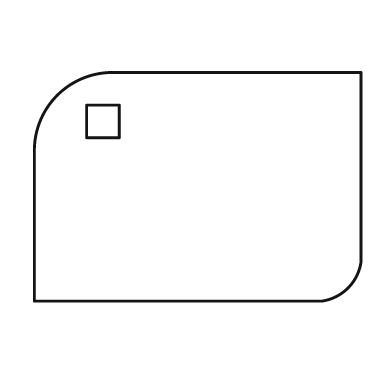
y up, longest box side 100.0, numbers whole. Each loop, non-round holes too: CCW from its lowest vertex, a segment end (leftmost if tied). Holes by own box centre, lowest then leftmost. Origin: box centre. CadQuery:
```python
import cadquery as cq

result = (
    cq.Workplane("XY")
    .moveTo(-50.0, -35.0)
    .lineTo(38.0, -35.0)
    .threePointArc((46.0, -31.0), (50.0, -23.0))
    .lineTo(50.0, 35.0)
    .lineTo(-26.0, 35.0)
    .threePointArc((-43.0, 28.0), (-50.0, 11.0))
    .close()
    .moveTo(-34.0, 15.0)
    .lineTo(-24.0, 15.0)
    .lineTo(-24.0, 25.0)
    .lineTo(-34.0, 25.0)
    .close()
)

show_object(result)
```